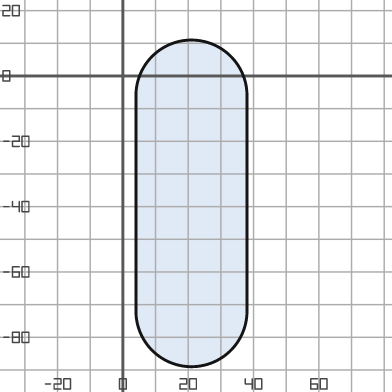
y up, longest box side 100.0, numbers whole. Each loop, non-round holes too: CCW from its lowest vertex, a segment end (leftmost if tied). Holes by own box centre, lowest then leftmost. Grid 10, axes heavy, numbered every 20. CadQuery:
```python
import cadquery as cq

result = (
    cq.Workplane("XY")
    .moveTo(4.0, -72.0)
    .threePointArc((21.0, -89.0), (38.0, -72.0))
    .lineTo(38.0, -6.0)
    .threePointArc((21.0, 11.0), (4.0, -6.0))
    .close()
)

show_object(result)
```